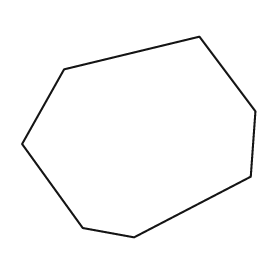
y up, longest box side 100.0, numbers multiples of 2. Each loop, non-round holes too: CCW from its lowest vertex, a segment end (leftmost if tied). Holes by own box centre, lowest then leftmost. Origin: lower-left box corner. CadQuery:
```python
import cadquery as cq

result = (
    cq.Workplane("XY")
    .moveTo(48.0, 0.0)
    .lineTo(98.0, 26.0)
    .lineTo(100.0, 54.0)
    .lineTo(76.0, 86.0)
    .lineTo(18.0, 72.0)
    .lineTo(0.0, 40.0)
    .lineTo(26.0, 4.0)
    .close()
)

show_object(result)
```